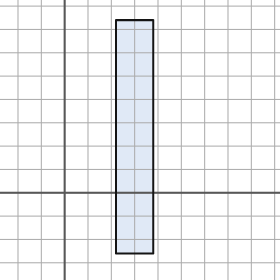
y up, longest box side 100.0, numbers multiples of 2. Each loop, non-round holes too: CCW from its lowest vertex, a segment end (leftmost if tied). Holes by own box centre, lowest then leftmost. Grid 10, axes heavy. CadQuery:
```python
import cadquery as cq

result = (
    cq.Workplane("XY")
    .moveTo(22.0, -26.0)
    .lineTo(38.0, -26.0)
    .lineTo(38.0, 74.0)
    .lineTo(22.0, 74.0)
    .close()
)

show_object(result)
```